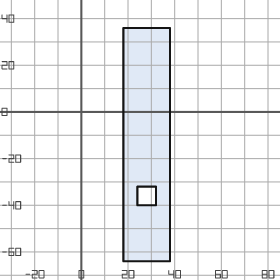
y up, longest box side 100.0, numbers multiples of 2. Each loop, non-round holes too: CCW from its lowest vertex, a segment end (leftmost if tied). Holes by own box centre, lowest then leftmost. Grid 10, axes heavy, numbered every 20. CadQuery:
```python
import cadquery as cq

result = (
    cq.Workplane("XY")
    .moveTo(18.0, -64.0)
    .lineTo(38.0, -64.0)
    .lineTo(38.0, 36.0)
    .lineTo(18.0, 36.0)
    .close()
    .moveTo(24.0, -40.0)
    .lineTo(32.0, -40.0)
    .lineTo(32.0, -32.0)
    .lineTo(24.0, -32.0)
    .close()
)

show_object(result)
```